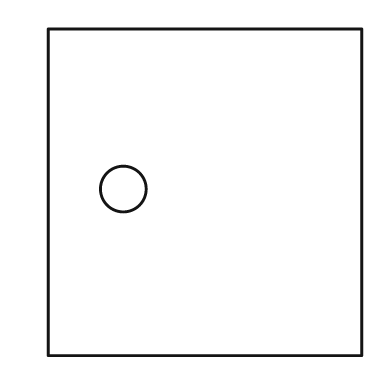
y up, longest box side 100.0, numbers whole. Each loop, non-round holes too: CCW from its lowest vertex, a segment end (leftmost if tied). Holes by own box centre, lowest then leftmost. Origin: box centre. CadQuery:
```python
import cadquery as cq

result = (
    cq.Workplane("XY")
    .moveTo(-48.0, -50.0)
    .lineTo(48.0, -50.0)
    .lineTo(48.0, 50.0)
    .lineTo(-48.0, 50.0)
    .close()
    .moveTo(-25.0, 1.0)
    .circle(7.0)
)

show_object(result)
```